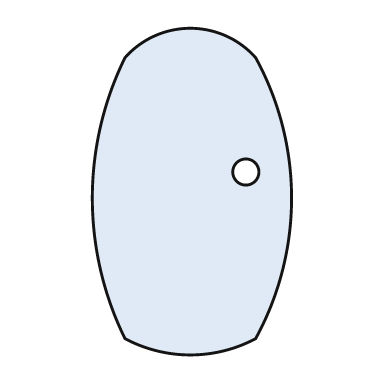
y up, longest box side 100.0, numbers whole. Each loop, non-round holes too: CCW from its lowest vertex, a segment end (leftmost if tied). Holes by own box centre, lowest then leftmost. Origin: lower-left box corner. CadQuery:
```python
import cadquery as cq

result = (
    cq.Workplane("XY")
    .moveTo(10.0, 5.0)
    .threePointArc((30.0, 0.0), (50.0, 5.0))
    .threePointArc((61.0, 48.0), (50.0, 91.0))
    .threePointArc((30.0, 100.0), (10.0, 91.0))
    .threePointArc((0.0, 48.0), (10.0, 5.0))
    .close()
    .moveTo(47.0, 56.0)
    .circle(4.0)
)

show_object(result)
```